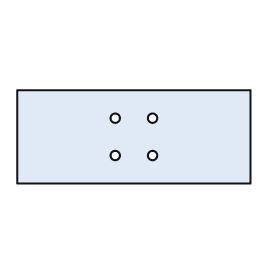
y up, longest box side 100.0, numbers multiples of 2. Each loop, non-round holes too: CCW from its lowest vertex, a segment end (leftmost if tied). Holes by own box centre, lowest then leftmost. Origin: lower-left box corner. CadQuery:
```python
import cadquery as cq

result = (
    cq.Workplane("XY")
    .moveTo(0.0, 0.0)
    .lineTo(100.0, 0.0)
    .lineTo(100.0, 40.0)
    .lineTo(0.0, 40.0)
    .close()
    .moveTo(42.0, 12.0)
    .circle(2.0)
    .moveTo(58.0, 12.0)
    .circle(2.0)
    .moveTo(42.0, 28.0)
    .circle(2.0)
    .moveTo(58.0, 28.0)
    .circle(2.0)
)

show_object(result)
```